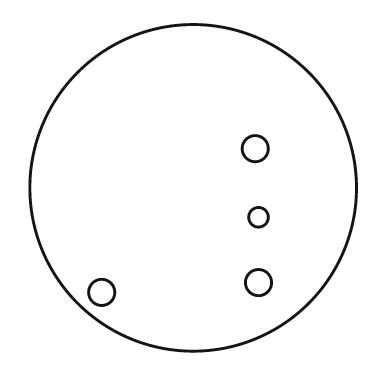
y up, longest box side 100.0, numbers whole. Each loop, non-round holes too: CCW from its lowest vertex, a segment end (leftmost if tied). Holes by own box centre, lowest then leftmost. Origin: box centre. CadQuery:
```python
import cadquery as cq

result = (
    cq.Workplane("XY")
    .moveTo(0.0, 0.0)
    .circle(50.0)
    .moveTo(-28.0, -32.0)
    .circle(4.0)
    .moveTo(20.0, -29.0)
    .circle(4.0)
    .moveTo(20.0, -9.0)
    .circle(3.0)
    .moveTo(19.0, 12.0)
    .circle(4.0)
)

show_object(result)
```